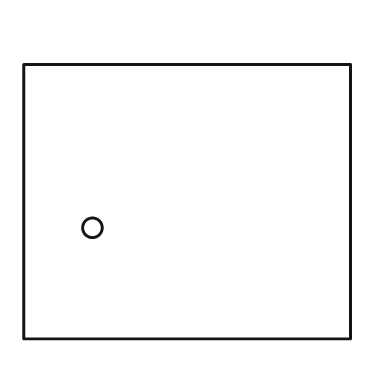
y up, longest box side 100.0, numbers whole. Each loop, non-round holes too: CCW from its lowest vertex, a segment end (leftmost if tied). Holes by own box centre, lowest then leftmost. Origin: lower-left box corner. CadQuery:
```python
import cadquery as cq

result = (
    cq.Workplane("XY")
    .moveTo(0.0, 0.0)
    .lineTo(100.0, 0.0)
    .lineTo(100.0, 84.0)
    .lineTo(0.0, 84.0)
    .close()
    .moveTo(21.0, 34.0)
    .circle(3.0)
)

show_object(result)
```